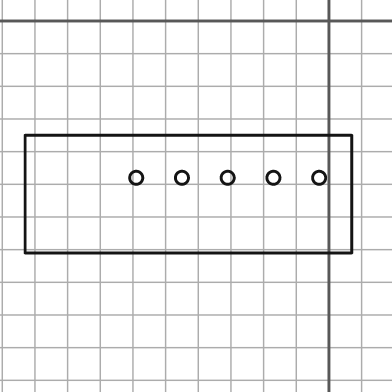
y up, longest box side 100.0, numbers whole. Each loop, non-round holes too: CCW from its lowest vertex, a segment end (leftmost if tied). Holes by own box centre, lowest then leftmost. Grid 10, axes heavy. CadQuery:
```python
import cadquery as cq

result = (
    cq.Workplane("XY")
    .moveTo(-93.0, -71.0)
    .lineTo(7.0, -71.0)
    .lineTo(7.0, -35.0)
    .lineTo(-93.0, -35.0)
    .close()
    .moveTo(-59.0, -48.0)
    .circle(2.0)
    .moveTo(-45.0, -48.0)
    .circle(2.0)
    .moveTo(-31.0, -48.0)
    .circle(2.0)
    .moveTo(-17.0, -48.0)
    .circle(2.0)
    .moveTo(-3.0, -48.0)
    .circle(2.0)
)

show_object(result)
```